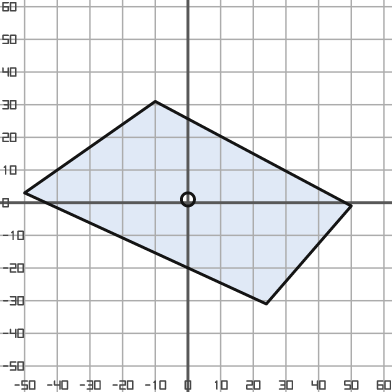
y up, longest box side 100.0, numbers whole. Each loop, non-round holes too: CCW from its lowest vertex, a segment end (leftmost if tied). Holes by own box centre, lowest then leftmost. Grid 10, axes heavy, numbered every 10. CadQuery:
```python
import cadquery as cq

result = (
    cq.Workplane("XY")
    .moveTo(24.0, -31.0)
    .lineTo(50.0, -1.0)
    .lineTo(-10.0, 31.0)
    .lineTo(-50.0, 3.0)
    .close()
    .moveTo(0.0, 1.0)
    .circle(2.0)
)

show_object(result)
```